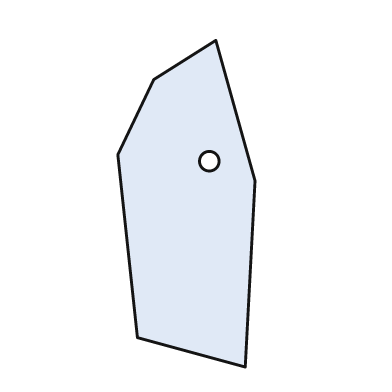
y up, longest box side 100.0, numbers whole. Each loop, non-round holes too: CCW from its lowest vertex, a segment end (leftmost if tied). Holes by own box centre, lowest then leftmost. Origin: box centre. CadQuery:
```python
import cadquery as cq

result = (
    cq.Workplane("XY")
    .moveTo(18.0, -50.0)
    .lineTo(21.0, 7.0)
    .lineTo(9.0, 50.0)
    .lineTo(-10.0, 38.0)
    .lineTo(-21.0, 15.0)
    .lineTo(-15.0, -41.0)
    .close()
    .moveTo(7.0, 13.0)
    .circle(3.0)
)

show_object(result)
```